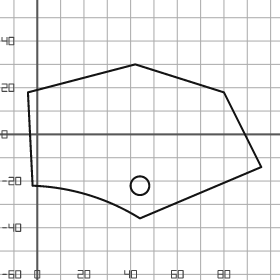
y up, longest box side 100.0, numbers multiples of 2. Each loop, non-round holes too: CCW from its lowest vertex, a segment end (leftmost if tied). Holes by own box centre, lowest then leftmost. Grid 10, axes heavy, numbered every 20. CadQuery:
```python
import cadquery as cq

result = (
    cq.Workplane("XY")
    .moveTo(44.0, -36.0)
    .lineTo(96.0, -14.0)
    .lineTo(80.0, 18.0)
    .lineTo(42.0, 30.0)
    .lineTo(-4.0, 18.0)
    .lineTo(-2.0, -22.0)
    .threePointArc((22.0, -26.0), (44.0, -36.0))
    .close()
    .moveTo(44.0, -22.0)
    .circle(4.0)
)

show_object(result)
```